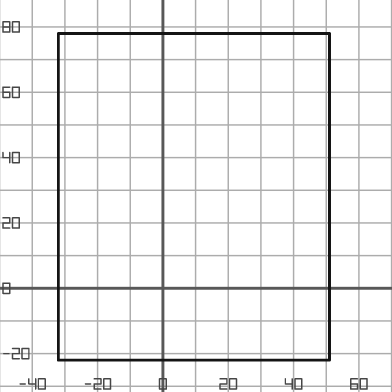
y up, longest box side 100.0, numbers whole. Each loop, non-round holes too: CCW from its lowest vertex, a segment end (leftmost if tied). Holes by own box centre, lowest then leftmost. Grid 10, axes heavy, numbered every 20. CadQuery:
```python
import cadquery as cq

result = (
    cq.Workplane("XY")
    .moveTo(-32.0, -22.0)
    .lineTo(51.0, -22.0)
    .lineTo(51.0, 78.0)
    .lineTo(-32.0, 78.0)
    .close()
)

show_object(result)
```